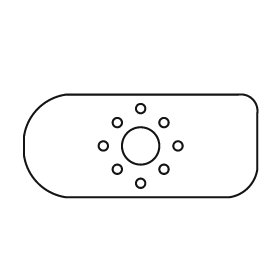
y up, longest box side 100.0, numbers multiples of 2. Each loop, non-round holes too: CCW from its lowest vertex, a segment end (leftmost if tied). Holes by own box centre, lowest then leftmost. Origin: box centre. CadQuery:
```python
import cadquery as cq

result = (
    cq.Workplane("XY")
    .moveTo(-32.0, -22.0)
    .lineTo(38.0, -22.0)
    .threePointArc((46.0, -18.0), (50.0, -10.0))
    .lineTo(50.0, 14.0)
    .threePointArc((48.0, 20.0), (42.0, 22.0))
    .lineTo(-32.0, 22.0)
    .threePointArc((-44.0, 16.0), (-50.0, 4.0))
    .lineTo(-50.0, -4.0)
    .threePointArc((-44.0, -16.0), (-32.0, -22.0))
    .close()
    .moveTo(0.0, -16.0)
    .circle(2.0)
    .moveTo(-10.0, -10.0)
    .circle(2.0)
    .moveTo(10.0, -10.0)
    .circle(2.0)
    .moveTo(-16.0, 0.0)
    .circle(2.0)
    .moveTo(0.0, 0.0)
    .circle(8.0)
    .moveTo(16.0, 0.0)
    .circle(2.0)
    .moveTo(-10.0, 10.0)
    .circle(2.0)
    .moveTo(10.0, 10.0)
    .circle(2.0)
    .moveTo(0.0, 16.0)
    .circle(2.0)
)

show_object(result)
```